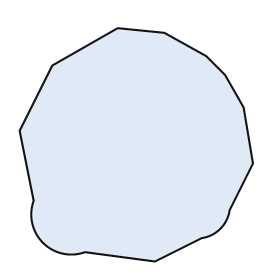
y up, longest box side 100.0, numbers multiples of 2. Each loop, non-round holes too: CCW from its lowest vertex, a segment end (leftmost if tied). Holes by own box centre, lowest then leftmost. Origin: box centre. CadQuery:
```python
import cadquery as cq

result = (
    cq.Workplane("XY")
    .moveTo(8.0, -50.0)
    .lineTo(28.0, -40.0)
    .threePointArc((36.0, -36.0), (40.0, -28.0))
    .lineTo(50.0, -8.0)
    .lineTo(46.0, 16.0)
    .lineTo(38.0, 30.0)
    .lineTo(30.0, 38.0)
    .lineTo(12.0, 48.0)
    .lineTo(-8.0, 50.0)
    .lineTo(-36.0, 34.0)
    .lineTo(-50.0, 6.0)
    .lineTo(-44.0, -24.0)
    .threePointArc((-40.0, -42.0), (-22.0, -46.0))
    .close()
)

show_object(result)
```